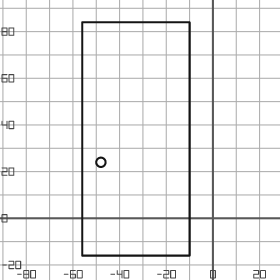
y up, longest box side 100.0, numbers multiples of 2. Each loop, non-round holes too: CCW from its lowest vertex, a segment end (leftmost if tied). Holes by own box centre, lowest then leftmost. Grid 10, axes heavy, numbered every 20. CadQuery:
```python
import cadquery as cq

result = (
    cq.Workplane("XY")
    .moveTo(-56.0, -16.0)
    .lineTo(-10.0, -16.0)
    .lineTo(-10.0, 84.0)
    .lineTo(-56.0, 84.0)
    .close()
    .moveTo(-48.0, 24.0)
    .circle(2.0)
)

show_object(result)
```